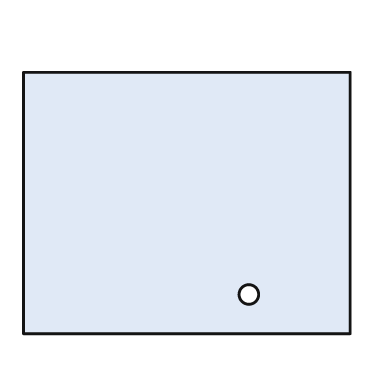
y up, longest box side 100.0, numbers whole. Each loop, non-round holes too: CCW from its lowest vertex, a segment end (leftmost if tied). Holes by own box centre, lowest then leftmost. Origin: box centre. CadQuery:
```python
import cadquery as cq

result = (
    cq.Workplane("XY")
    .moveTo(-50.0, -40.0)
    .lineTo(50.0, -40.0)
    .lineTo(50.0, 40.0)
    .lineTo(-50.0, 40.0)
    .close()
    .moveTo(19.0, -28.0)
    .circle(3.0)
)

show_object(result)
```